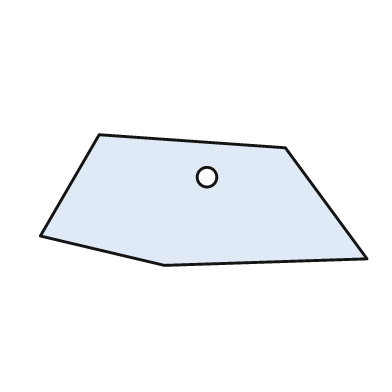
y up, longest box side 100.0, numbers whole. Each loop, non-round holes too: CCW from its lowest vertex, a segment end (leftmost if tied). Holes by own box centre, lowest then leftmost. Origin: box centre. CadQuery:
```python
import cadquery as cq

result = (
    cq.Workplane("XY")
    .moveTo(-12.0, -20.0)
    .lineTo(50.0, -18.0)
    .lineTo(25.0, 16.0)
    .lineTo(-32.0, 20.0)
    .lineTo(-50.0, -11.0)
    .close()
    .moveTo(1.0, 7.0)
    .circle(3.0)
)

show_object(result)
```